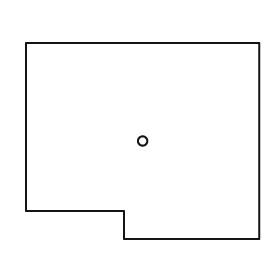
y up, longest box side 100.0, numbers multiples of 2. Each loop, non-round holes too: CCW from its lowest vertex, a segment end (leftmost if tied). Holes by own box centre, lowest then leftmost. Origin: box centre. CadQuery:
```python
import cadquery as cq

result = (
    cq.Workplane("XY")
    .moveTo(-8.0, -42.0)
    .lineTo(50.0, -42.0)
    .lineTo(50.0, 42.0)
    .lineTo(-50.0, 42.0)
    .lineTo(-50.0, -30.0)
    .lineTo(-8.0, -30.0)
    .close()
    .moveTo(0.0, 0.0)
    .circle(2.0)
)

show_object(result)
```